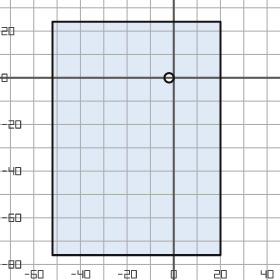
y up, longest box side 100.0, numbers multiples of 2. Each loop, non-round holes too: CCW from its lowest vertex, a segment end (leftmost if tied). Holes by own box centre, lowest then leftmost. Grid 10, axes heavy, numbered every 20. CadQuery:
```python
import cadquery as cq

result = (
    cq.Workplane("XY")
    .moveTo(-52.0, -76.0)
    .lineTo(20.0, -76.0)
    .lineTo(20.0, 24.0)
    .lineTo(-52.0, 24.0)
    .close()
    .moveTo(-2.0, 0.0)
    .circle(2.0)
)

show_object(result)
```